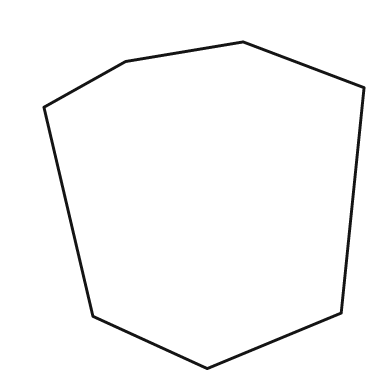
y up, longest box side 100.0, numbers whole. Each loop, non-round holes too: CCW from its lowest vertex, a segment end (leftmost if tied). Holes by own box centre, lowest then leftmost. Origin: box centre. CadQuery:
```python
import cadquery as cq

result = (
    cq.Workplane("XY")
    .moveTo(1.0, -50.0)
    .lineTo(42.0, -33.0)
    .lineTo(49.0, 36.0)
    .lineTo(12.0, 50.0)
    .lineTo(-24.0, 44.0)
    .lineTo(-49.0, 30.0)
    .lineTo(-34.0, -34.0)
    .close()
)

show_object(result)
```